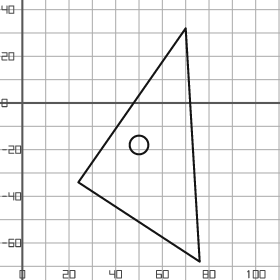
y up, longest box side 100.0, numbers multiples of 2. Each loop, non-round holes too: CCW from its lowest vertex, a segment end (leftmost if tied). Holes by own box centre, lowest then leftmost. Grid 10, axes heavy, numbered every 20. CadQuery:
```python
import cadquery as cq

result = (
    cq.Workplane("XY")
    .moveTo(76.0, -68.0)
    .lineTo(70.0, 32.0)
    .lineTo(24.0, -34.0)
    .close()
    .moveTo(50.0, -18.0)
    .circle(4.0)
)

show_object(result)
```